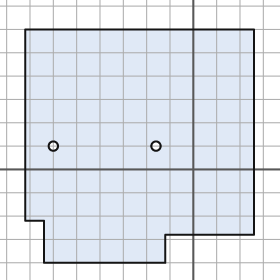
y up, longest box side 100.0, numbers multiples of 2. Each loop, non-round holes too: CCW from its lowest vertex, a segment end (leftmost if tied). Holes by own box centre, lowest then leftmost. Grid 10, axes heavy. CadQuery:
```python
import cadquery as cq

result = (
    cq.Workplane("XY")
    .moveTo(-64.0, -40.0)
    .lineTo(-12.0, -40.0)
    .lineTo(-12.0, -28.0)
    .lineTo(26.0, -28.0)
    .lineTo(26.0, 60.0)
    .lineTo(-72.0, 60.0)
    .lineTo(-72.0, -22.0)
    .lineTo(-64.0, -22.0)
    .close()
    .moveTo(-60.0, 10.0)
    .circle(2.0)
    .moveTo(-16.0, 10.0)
    .circle(2.0)
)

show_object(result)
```